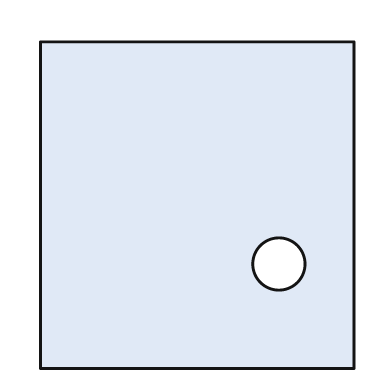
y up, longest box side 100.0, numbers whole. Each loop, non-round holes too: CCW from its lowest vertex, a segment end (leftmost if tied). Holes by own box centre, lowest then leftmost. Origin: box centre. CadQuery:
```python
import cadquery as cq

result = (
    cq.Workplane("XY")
    .moveTo(-48.0, -50.0)
    .lineTo(48.0, -50.0)
    .lineTo(48.0, 50.0)
    .lineTo(-48.0, 50.0)
    .close()
    .moveTo(25.0, -18.0)
    .circle(8.0)
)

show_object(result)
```